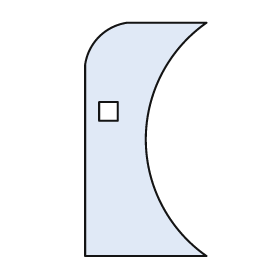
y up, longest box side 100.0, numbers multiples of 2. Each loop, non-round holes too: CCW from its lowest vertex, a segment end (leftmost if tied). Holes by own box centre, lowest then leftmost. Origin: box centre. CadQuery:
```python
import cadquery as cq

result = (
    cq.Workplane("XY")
    .moveTo(-26.0, -50.0)
    .lineTo(26.0, -50.0)
    .threePointArc((0.0, 0.0), (26.0, 50.0))
    .lineTo(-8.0, 50.0)
    .threePointArc((-20.0, 44.0), (-26.0, 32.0))
    .close()
    .moveTo(-20.0, 8.0)
    .lineTo(-12.0, 8.0)
    .lineTo(-12.0, 16.0)
    .lineTo(-20.0, 16.0)
    .close()
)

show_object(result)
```